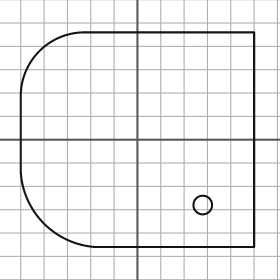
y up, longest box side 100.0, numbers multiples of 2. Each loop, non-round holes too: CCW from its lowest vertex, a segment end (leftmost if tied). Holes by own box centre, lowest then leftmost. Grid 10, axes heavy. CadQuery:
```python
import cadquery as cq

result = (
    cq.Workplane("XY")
    .moveTo(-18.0, -46.0)
    .lineTo(50.0, -46.0)
    .lineTo(50.0, 46.0)
    .lineTo(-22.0, 46.0)
    .threePointArc((-42.0, 38.0), (-50.0, 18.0))
    .lineTo(-50.0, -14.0)
    .threePointArc((-40.0, -36.0), (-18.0, -46.0))
    .close()
    .moveTo(28.0, -28.0)
    .circle(4.0)
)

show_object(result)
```